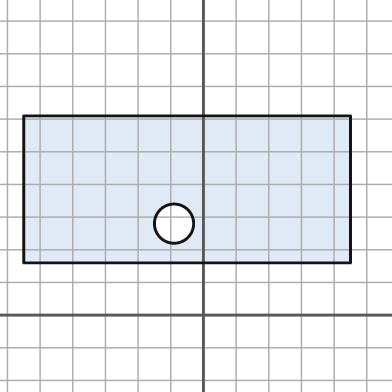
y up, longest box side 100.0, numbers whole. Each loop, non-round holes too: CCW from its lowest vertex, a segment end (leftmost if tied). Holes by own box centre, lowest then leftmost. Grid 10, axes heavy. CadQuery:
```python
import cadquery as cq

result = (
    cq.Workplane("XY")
    .moveTo(-55.0, 16.0)
    .lineTo(45.0, 16.0)
    .lineTo(45.0, 61.0)
    .lineTo(-55.0, 61.0)
    .close()
    .moveTo(-9.0, 28.0)
    .circle(6.0)
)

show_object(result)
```